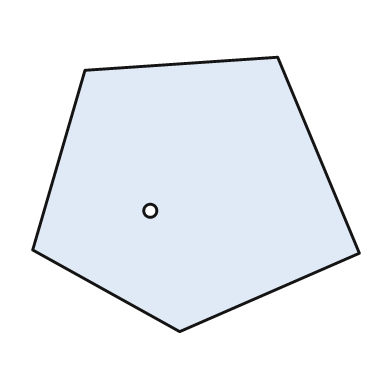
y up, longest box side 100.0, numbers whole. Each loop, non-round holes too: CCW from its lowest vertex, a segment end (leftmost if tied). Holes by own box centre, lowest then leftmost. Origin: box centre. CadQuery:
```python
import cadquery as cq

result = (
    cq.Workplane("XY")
    .moveTo(-5.0, -42.0)
    .lineTo(50.0, -18.0)
    .lineTo(25.0, 42.0)
    .lineTo(-34.0, 38.0)
    .lineTo(-50.0, -17.0)
    .close()
    .moveTo(-14.0, -5.0)
    .circle(2.0)
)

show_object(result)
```